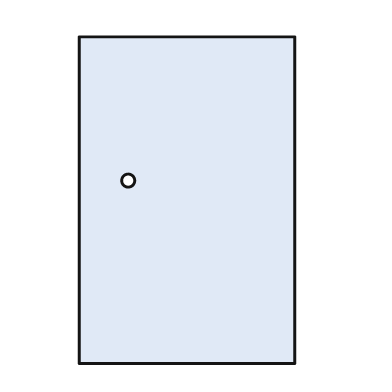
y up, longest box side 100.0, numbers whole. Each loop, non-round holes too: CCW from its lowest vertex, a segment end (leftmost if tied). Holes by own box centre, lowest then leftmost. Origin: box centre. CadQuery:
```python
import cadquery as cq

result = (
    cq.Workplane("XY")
    .moveTo(-33.0, -50.0)
    .lineTo(33.0, -50.0)
    .lineTo(33.0, 50.0)
    .lineTo(-33.0, 50.0)
    .close()
    .moveTo(-18.0, 6.0)
    .circle(2.0)
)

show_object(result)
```